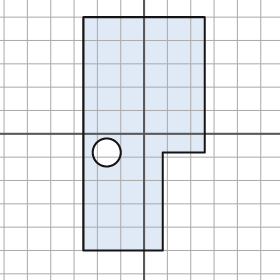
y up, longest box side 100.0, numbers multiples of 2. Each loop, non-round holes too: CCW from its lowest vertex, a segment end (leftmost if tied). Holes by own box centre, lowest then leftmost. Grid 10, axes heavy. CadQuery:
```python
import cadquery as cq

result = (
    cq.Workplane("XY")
    .moveTo(-26.0, -50.0)
    .lineTo(8.0, -50.0)
    .lineTo(8.0, -8.0)
    .lineTo(26.0, -8.0)
    .lineTo(26.0, 50.0)
    .lineTo(-26.0, 50.0)
    .close()
    .moveTo(-16.0, -8.0)
    .circle(6.0)
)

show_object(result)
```